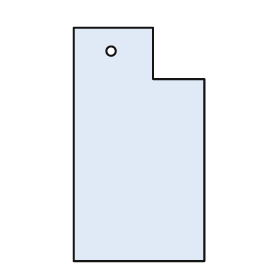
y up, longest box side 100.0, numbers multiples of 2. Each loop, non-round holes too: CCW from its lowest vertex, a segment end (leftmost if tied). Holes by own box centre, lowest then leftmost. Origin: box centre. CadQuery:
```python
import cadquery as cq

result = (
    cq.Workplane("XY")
    .moveTo(-28.0, -50.0)
    .lineTo(28.0, -50.0)
    .lineTo(28.0, 28.0)
    .lineTo(6.0, 28.0)
    .lineTo(6.0, 50.0)
    .lineTo(-28.0, 50.0)
    .close()
    .moveTo(-12.0, 40.0)
    .circle(2.0)
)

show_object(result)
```